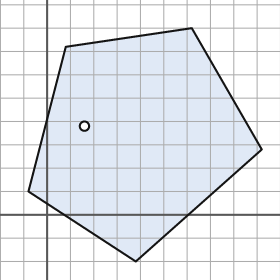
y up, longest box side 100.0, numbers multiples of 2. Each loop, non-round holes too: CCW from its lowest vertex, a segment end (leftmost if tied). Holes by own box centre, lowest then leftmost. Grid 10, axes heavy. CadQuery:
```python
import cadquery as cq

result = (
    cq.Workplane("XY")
    .moveTo(38.0, -20.0)
    .lineTo(92.0, 28.0)
    .lineTo(62.0, 80.0)
    .lineTo(8.0, 72.0)
    .lineTo(-8.0, 10.0)
    .close()
    .moveTo(16.0, 38.0)
    .circle(2.0)
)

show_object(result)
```